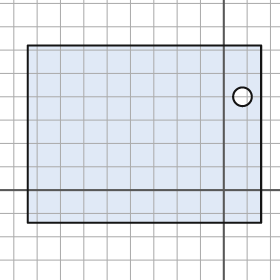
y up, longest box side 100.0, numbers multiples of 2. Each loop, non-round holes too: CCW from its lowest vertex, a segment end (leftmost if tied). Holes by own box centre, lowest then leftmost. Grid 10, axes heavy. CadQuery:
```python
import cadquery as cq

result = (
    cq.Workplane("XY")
    .moveTo(-84.0, -14.0)
    .lineTo(16.0, -14.0)
    .lineTo(16.0, 62.0)
    .lineTo(-84.0, 62.0)
    .close()
    .moveTo(8.0, 40.0)
    .circle(4.0)
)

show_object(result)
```